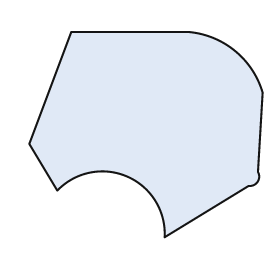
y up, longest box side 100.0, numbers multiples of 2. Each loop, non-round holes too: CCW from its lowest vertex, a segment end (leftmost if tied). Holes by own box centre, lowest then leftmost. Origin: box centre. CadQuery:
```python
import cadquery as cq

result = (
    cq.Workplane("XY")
    .moveTo(8.0, -44.0)
    .lineTo(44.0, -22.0)
    .threePointArc((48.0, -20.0), (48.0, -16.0))
    .lineTo(50.0, 18.0)
    .threePointArc((38.0, 36.0), (18.0, 44.0))
    .lineTo(-32.0, 44.0)
    .lineTo(-50.0, -4.0)
    .lineTo(-38.0, -24.0)
    .threePointArc((-8.0, -18.0), (8.0, -44.0))
    .close()
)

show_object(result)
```